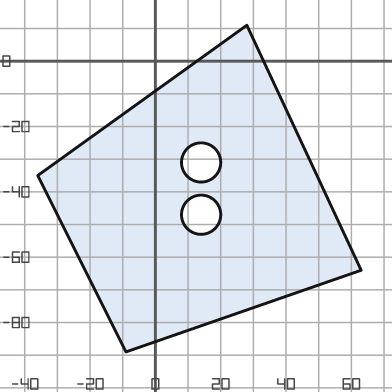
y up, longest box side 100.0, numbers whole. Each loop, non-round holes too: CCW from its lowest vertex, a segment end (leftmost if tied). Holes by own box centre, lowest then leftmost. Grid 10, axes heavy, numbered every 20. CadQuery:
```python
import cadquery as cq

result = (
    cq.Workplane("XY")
    .moveTo(-9.0, -89.0)
    .lineTo(63.0, -64.0)
    .lineTo(28.0, 11.0)
    .lineTo(-36.0, -35.0)
    .close()
    .moveTo(14.0, -47.0)
    .circle(6.0)
    .moveTo(14.0, -31.0)
    .circle(6.0)
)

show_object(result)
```